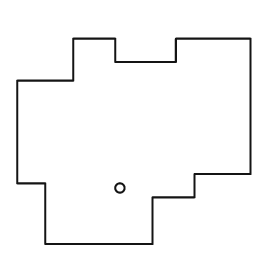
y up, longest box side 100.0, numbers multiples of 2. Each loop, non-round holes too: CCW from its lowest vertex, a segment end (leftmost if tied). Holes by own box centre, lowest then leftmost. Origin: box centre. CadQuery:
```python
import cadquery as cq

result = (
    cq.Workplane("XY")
    .moveTo(-38.0, -44.0)
    .lineTo(8.0, -44.0)
    .lineTo(8.0, -24.0)
    .lineTo(26.0, -24.0)
    .lineTo(26.0, -14.0)
    .lineTo(50.0, -14.0)
    .lineTo(50.0, 44.0)
    .lineTo(18.0, 44.0)
    .lineTo(18.0, 34.0)
    .lineTo(-8.0, 34.0)
    .lineTo(-8.0, 44.0)
    .lineTo(-26.0, 44.0)
    .lineTo(-26.0, 26.0)
    .lineTo(-50.0, 26.0)
    .lineTo(-50.0, -18.0)
    .lineTo(-38.0, -18.0)
    .close()
    .moveTo(-6.0, -20.0)
    .circle(2.0)
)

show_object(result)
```